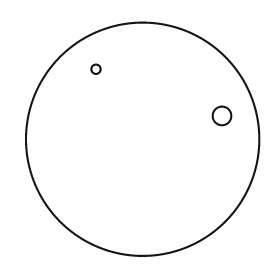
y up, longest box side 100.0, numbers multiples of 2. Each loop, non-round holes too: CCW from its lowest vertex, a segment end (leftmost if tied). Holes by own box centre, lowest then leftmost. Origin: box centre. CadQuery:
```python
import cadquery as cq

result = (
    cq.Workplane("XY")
    .moveTo(0.0, 0.0)
    .circle(50.0)
    .moveTo(34.0, 10.0)
    .circle(4.0)
    .moveTo(-20.0, 30.0)
    .circle(2.0)
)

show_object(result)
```